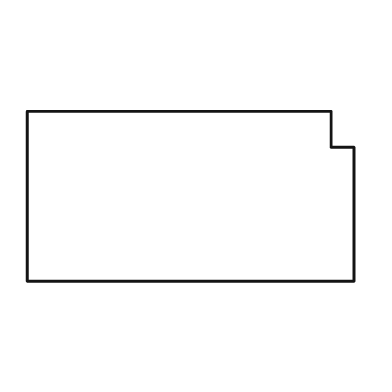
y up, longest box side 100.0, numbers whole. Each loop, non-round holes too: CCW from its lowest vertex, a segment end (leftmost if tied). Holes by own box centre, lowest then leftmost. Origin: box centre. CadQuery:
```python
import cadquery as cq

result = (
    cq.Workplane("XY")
    .moveTo(-50.0, -26.0)
    .lineTo(50.0, -26.0)
    .lineTo(50.0, 15.0)
    .lineTo(43.0, 15.0)
    .lineTo(43.0, 26.0)
    .lineTo(-50.0, 26.0)
    .close()
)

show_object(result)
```